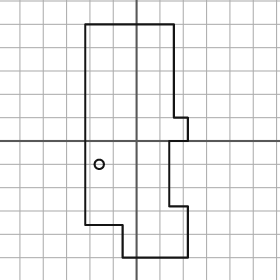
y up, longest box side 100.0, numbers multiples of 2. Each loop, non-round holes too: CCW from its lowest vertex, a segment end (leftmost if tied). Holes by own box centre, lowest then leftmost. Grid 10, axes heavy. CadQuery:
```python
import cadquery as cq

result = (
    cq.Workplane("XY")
    .moveTo(-6.0, -50.0)
    .lineTo(22.0, -50.0)
    .lineTo(22.0, -28.0)
    .lineTo(14.0, -28.0)
    .lineTo(14.0, 0.0)
    .lineTo(22.0, 0.0)
    .lineTo(22.0, 10.0)
    .lineTo(16.0, 10.0)
    .lineTo(16.0, 50.0)
    .lineTo(-22.0, 50.0)
    .lineTo(-22.0, -36.0)
    .lineTo(-6.0, -36.0)
    .close()
    .moveTo(-16.0, -10.0)
    .circle(2.0)
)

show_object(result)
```